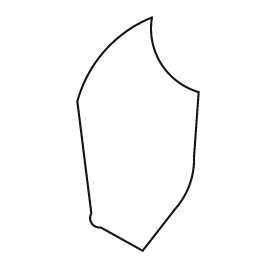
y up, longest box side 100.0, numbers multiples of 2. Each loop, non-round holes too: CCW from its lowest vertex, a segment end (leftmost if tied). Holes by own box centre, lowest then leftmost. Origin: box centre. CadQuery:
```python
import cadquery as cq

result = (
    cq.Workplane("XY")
    .moveTo(2.0, -50.0)
    .lineTo(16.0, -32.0)
    .threePointArc((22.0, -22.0), (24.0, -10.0))
    .lineTo(26.0, 18.0)
    .threePointArc((10.0, 30.0), (6.0, 50.0))
    .threePointArc((-14.0, 36.0), (-26.0, 14.0))
    .lineTo(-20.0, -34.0)
    .threePointArc((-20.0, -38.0), (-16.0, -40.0))
    .close()
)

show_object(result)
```